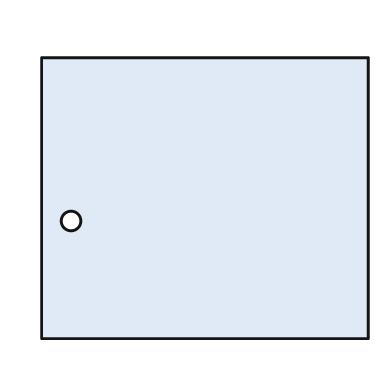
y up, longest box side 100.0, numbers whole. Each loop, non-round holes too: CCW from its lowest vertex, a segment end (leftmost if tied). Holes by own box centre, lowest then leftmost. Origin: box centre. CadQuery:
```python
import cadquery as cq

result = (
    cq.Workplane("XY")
    .moveTo(-50.0, -43.0)
    .lineTo(50.0, -43.0)
    .lineTo(50.0, 43.0)
    .lineTo(-50.0, 43.0)
    .close()
    .moveTo(-41.0, -7.0)
    .circle(3.0)
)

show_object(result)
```